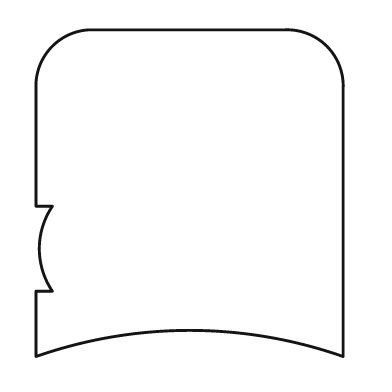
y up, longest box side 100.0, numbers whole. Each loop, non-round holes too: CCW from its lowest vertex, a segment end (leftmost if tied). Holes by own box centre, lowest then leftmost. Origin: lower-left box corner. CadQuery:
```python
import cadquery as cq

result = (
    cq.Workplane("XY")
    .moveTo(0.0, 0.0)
    .threePointArc((47.0, 8.0), (94.0, 0.0))
    .lineTo(94.0, 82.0)
    .threePointArc((89.0, 95.0), (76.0, 100.0))
    .lineTo(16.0, 100.0)
    .threePointArc((5.0, 95.0), (0.0, 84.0))
    .lineTo(0.0, 46.0)
    .lineTo(5.0, 46.0)
    .threePointArc((1.0, 33.0), (5.0, 20.0))
    .lineTo(0.0, 20.0)
    .close()
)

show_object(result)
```